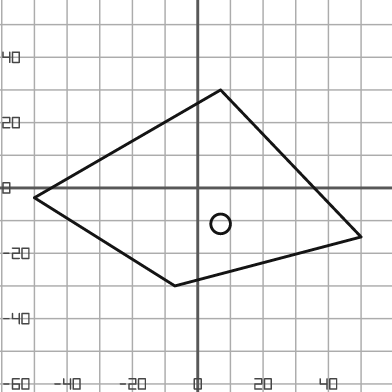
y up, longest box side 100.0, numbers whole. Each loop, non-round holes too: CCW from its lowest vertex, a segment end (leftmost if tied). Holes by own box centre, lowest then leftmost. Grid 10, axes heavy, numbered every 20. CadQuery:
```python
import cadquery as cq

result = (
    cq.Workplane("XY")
    .moveTo(-7.0, -30.0)
    .lineTo(50.0, -15.0)
    .lineTo(7.0, 30.0)
    .lineTo(-50.0, -3.0)
    .close()
    .moveTo(7.0, -11.0)
    .circle(3.0)
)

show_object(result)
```